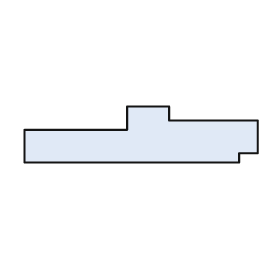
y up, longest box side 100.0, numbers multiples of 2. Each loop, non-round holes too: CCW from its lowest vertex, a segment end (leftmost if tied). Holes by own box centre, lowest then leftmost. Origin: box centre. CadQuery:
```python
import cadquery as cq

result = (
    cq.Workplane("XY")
    .moveTo(-50.0, -12.0)
    .lineTo(42.0, -12.0)
    .lineTo(42.0, -8.0)
    .lineTo(50.0, -8.0)
    .lineTo(50.0, 6.0)
    .lineTo(12.0, 6.0)
    .lineTo(12.0, 12.0)
    .lineTo(-6.0, 12.0)
    .lineTo(-6.0, 2.0)
    .lineTo(-50.0, 2.0)
    .close()
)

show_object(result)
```